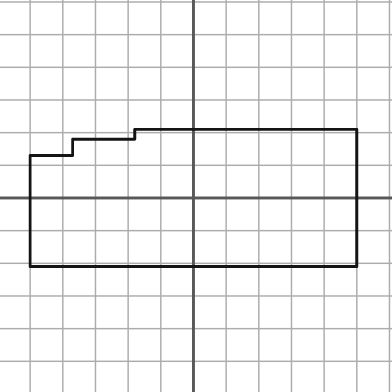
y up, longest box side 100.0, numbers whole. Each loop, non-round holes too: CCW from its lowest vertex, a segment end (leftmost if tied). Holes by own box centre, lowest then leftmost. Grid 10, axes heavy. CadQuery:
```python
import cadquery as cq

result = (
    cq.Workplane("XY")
    .moveTo(-50.0, -21.0)
    .lineTo(50.0, -21.0)
    .lineTo(50.0, 21.0)
    .lineTo(-18.0, 21.0)
    .lineTo(-18.0, 18.0)
    .lineTo(-37.0, 18.0)
    .lineTo(-37.0, 13.0)
    .lineTo(-50.0, 13.0)
    .close()
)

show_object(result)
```